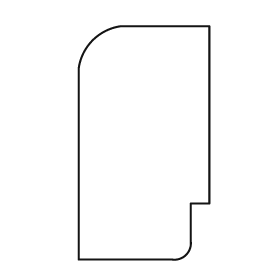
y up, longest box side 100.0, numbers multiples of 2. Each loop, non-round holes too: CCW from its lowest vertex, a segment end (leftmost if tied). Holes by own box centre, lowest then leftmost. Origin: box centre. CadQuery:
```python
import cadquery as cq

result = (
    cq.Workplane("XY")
    .moveTo(-28.0, -50.0)
    .lineTo(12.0, -50.0)
    .threePointArc((18.0, -48.0), (20.0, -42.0))
    .lineTo(20.0, -26.0)
    .lineTo(28.0, -26.0)
    .lineTo(28.0, 50.0)
    .lineTo(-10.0, 50.0)
    .threePointArc((-22.0, 44.0), (-28.0, 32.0))
    .close()
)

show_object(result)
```